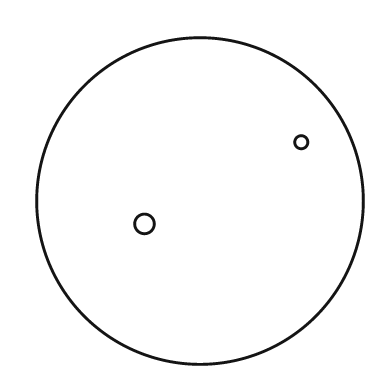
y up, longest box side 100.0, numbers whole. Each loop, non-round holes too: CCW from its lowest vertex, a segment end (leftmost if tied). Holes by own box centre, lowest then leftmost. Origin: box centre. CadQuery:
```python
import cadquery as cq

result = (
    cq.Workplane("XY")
    .moveTo(0.0, 0.0)
    .circle(50.0)
    .moveTo(-17.0, -7.0)
    .circle(3.0)
    .moveTo(31.0, 18.0)
    .circle(2.0)
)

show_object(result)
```